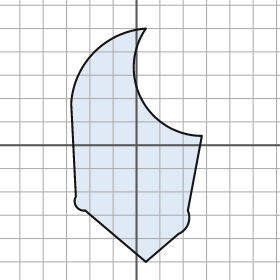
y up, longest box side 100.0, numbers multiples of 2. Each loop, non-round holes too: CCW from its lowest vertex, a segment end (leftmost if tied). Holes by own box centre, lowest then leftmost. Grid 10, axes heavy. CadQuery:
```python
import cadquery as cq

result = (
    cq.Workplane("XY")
    .moveTo(4.0, -50.0)
    .lineTo(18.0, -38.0)
    .threePointArc((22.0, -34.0), (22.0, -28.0))
    .lineTo(28.0, 4.0)
    .threePointArc((2.0, 20.0), (4.0, 50.0))
    .threePointArc((-18.0, 40.0), (-28.0, 18.0))
    .lineTo(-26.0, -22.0)
    .threePointArc((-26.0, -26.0), (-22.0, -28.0))
    .close()
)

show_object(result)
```